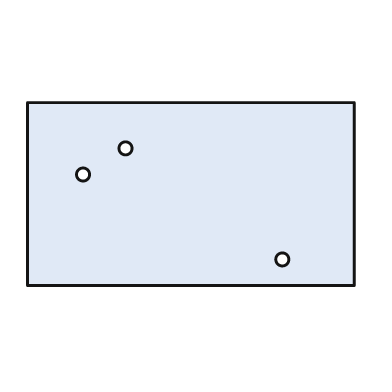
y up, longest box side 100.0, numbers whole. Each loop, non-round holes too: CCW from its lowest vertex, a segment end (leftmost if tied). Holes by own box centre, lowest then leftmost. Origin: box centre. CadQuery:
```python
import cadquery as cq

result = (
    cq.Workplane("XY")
    .moveTo(-50.0, -28.0)
    .lineTo(50.0, -28.0)
    .lineTo(50.0, 28.0)
    .lineTo(-50.0, 28.0)
    .close()
    .moveTo(28.0, -20.0)
    .circle(2.0)
    .moveTo(-33.0, 6.0)
    .circle(2.0)
    .moveTo(-20.0, 14.0)
    .circle(2.0)
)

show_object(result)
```